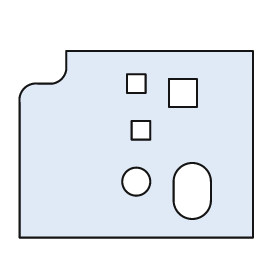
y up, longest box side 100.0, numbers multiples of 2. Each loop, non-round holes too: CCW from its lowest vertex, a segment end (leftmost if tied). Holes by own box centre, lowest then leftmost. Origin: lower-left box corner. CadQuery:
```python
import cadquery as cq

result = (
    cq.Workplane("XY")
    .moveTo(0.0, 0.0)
    .lineTo(100.0, 0.0)
    .lineTo(100.0, 80.0)
    .lineTo(20.0, 80.0)
    .lineTo(20.0, 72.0)
    .threePointArc((18.0, 68.0), (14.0, 66.0))
    .lineTo(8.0, 66.0)
    .threePointArc((2.0, 64.0), (0.0, 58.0))
    .close()
    .moveTo(66.0, 16.0)
    .threePointArc((74.0, 8.0), (82.0, 16.0))
    .lineTo(82.0, 24.0)
    .threePointArc((74.0, 32.0), (66.0, 24.0))
    .close()
    .moveTo(50.0, 24.0)
    .circle(6.0)
    .moveTo(48.0, 42.0)
    .lineTo(56.0, 42.0)
    .lineTo(56.0, 50.0)
    .lineTo(48.0, 50.0)
    .close()
    .moveTo(64.0, 56.0)
    .lineTo(76.0, 56.0)
    .lineTo(76.0, 68.0)
    .lineTo(64.0, 68.0)
    .close()
    .moveTo(46.0, 62.0)
    .lineTo(54.0, 62.0)
    .lineTo(54.0, 70.0)
    .lineTo(46.0, 70.0)
    .close()
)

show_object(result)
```